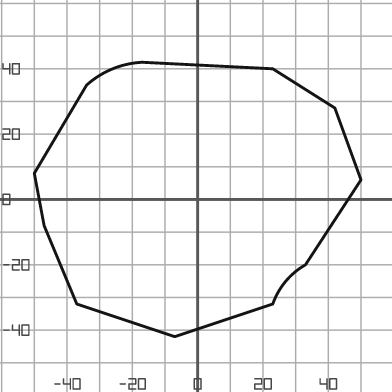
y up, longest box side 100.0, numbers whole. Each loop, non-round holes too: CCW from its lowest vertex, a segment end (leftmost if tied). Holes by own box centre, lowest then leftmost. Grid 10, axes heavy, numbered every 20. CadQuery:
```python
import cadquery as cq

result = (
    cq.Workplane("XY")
    .moveTo(-7.0, -42.0)
    .lineTo(23.0, -32.0)
    .threePointArc((27.0, -25.0), (33.0, -20.0))
    .lineTo(50.0, 6.0)
    .lineTo(42.0, 28.0)
    .lineTo(23.0, 40.0)
    .lineTo(-17.0, 42.0)
    .threePointArc((-26.0, 40.0), (-34.0, 35.0))
    .lineTo(-50.0, 8.0)
    .lineTo(-47.0, -8.0)
    .lineTo(-37.0, -32.0)
    .close()
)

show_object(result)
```